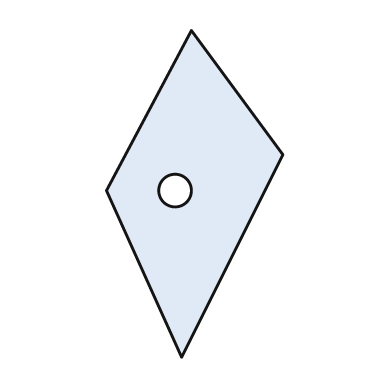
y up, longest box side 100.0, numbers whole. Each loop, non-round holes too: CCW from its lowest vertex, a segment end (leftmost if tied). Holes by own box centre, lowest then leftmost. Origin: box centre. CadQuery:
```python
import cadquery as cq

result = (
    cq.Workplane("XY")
    .moveTo(-4.0, -50.0)
    .lineTo(27.0, 12.0)
    .lineTo(-1.0, 50.0)
    .lineTo(-27.0, 1.0)
    .close()
    .moveTo(-6.0, 1.0)
    .circle(5.0)
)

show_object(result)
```